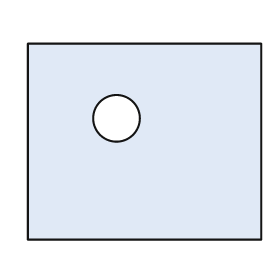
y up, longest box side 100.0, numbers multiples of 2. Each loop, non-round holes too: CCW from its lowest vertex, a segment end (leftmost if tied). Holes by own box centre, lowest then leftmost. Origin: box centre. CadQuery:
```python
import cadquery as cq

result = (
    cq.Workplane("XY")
    .moveTo(-50.0, -42.0)
    .lineTo(50.0, -42.0)
    .lineTo(50.0, 42.0)
    .lineTo(-50.0, 42.0)
    .close()
    .moveTo(-12.0, 10.0)
    .circle(10.0)
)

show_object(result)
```